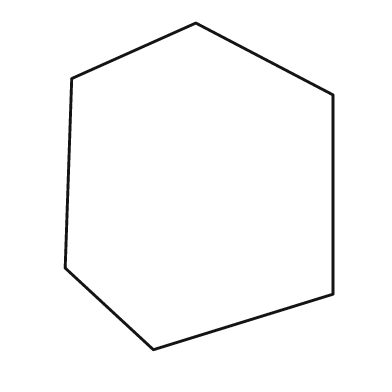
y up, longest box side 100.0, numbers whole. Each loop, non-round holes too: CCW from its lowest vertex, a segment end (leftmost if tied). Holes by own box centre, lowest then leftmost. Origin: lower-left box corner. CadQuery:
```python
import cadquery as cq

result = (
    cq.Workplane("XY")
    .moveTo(27.0, 0.0)
    .lineTo(82.0, 17.0)
    .lineTo(82.0, 78.0)
    .lineTo(40.0, 100.0)
    .lineTo(2.0, 83.0)
    .lineTo(0.0, 25.0)
    .close()
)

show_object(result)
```